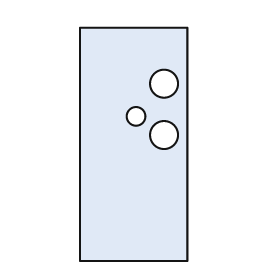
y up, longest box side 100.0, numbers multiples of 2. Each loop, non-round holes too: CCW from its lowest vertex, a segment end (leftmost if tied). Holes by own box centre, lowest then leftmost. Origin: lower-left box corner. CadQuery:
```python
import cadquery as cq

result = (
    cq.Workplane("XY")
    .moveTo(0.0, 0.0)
    .lineTo(46.0, 0.0)
    .lineTo(46.0, 100.0)
    .lineTo(0.0, 100.0)
    .close()
    .moveTo(36.0, 54.0)
    .circle(6.0)
    .moveTo(24.0, 62.0)
    .circle(4.0)
    .moveTo(36.0, 76.0)
    .circle(6.0)
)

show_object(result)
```